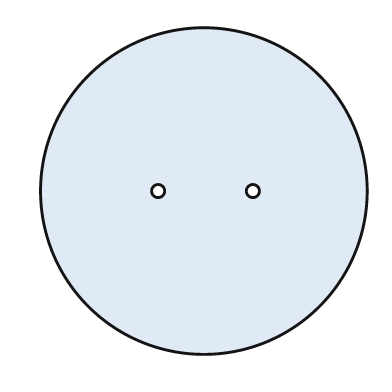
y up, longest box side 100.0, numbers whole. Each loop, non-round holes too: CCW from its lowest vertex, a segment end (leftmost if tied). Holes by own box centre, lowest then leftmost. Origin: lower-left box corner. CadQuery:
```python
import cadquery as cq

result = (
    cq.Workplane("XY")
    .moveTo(50.0, 50.0)
    .circle(50.0)
    .moveTo(36.0, 50.0)
    .circle(2.0)
    .moveTo(65.0, 50.0)
    .circle(2.0)
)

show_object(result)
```